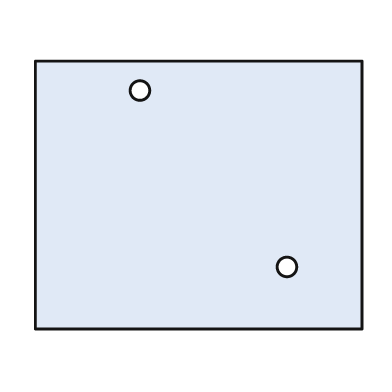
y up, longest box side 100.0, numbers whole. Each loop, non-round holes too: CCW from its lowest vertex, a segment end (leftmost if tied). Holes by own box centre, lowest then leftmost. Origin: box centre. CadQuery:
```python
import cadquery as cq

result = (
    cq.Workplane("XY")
    .moveTo(-50.0, -41.0)
    .lineTo(50.0, -41.0)
    .lineTo(50.0, 41.0)
    .lineTo(-50.0, 41.0)
    .close()
    .moveTo(27.0, -22.0)
    .circle(3.0)
    .moveTo(-18.0, 32.0)
    .circle(3.0)
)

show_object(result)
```